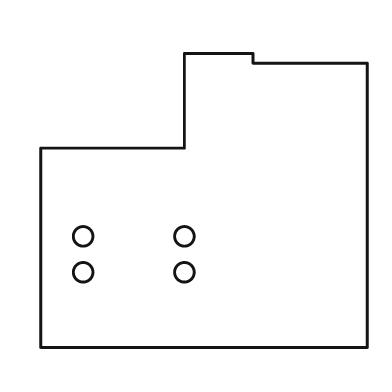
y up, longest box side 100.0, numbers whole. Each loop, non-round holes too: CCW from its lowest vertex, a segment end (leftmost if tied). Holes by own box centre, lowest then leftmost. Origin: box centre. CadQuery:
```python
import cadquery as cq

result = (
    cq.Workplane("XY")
    .moveTo(-50.0, -45.0)
    .lineTo(50.0, -45.0)
    .lineTo(50.0, 42.0)
    .lineTo(15.0, 42.0)
    .lineTo(15.0, 45.0)
    .lineTo(-6.0, 45.0)
    .lineTo(-6.0, 16.0)
    .lineTo(-50.0, 16.0)
    .close()
    .moveTo(-37.0, -22.0)
    .circle(3.0)
    .moveTo(-6.0, -22.0)
    .circle(3.0)
    .moveTo(-37.0, -11.0)
    .circle(3.0)
    .moveTo(-6.0, -11.0)
    .circle(3.0)
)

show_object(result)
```